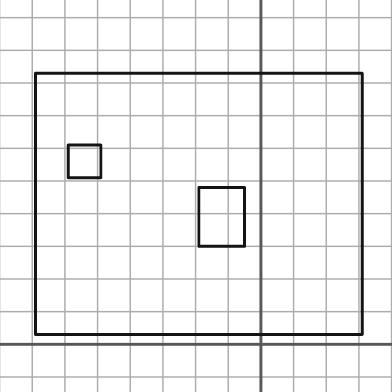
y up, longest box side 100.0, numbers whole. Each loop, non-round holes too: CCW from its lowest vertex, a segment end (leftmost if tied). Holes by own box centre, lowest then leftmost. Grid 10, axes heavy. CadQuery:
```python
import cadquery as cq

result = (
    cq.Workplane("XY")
    .moveTo(-69.0, 3.0)
    .lineTo(31.0, 3.0)
    .lineTo(31.0, 83.0)
    .lineTo(-69.0, 83.0)
    .close()
    .moveTo(-19.0, 30.0)
    .lineTo(-5.0, 30.0)
    .lineTo(-5.0, 48.0)
    .lineTo(-19.0, 48.0)
    .close()
    .moveTo(-59.0, 51.0)
    .lineTo(-49.0, 51.0)
    .lineTo(-49.0, 61.0)
    .lineTo(-59.0, 61.0)
    .close()
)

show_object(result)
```